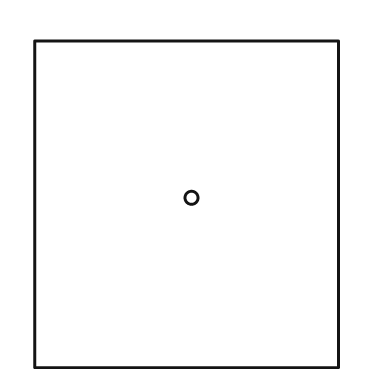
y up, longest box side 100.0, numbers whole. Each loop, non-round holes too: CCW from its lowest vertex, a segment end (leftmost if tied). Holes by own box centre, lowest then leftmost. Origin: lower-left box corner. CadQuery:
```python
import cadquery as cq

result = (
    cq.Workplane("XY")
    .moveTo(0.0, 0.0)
    .lineTo(93.0, 0.0)
    .lineTo(93.0, 100.0)
    .lineTo(0.0, 100.0)
    .close()
    .moveTo(48.0, 52.0)
    .circle(2.0)
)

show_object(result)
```